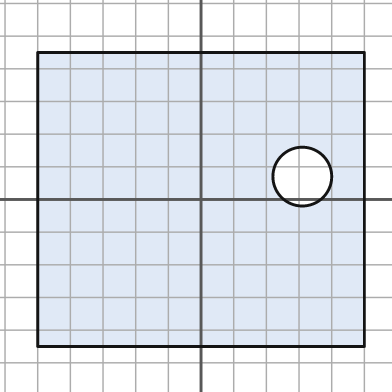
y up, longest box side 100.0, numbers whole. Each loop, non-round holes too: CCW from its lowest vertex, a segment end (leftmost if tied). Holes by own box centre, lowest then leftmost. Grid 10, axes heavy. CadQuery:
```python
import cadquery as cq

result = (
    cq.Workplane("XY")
    .moveTo(-50.0, -45.0)
    .lineTo(50.0, -45.0)
    .lineTo(50.0, 45.0)
    .lineTo(-50.0, 45.0)
    .close()
    .moveTo(31.0, 7.0)
    .circle(9.0)
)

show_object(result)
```